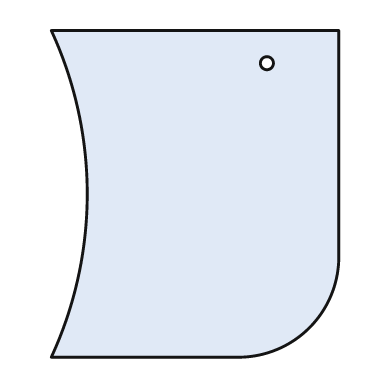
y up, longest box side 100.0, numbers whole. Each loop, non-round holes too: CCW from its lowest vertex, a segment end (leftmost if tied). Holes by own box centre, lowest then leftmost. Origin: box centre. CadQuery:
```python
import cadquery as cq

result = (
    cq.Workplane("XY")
    .moveTo(-44.0, -50.0)
    .lineTo(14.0, -50.0)
    .threePointArc((35.0, -41.0), (44.0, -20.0))
    .lineTo(44.0, 50.0)
    .lineTo(-44.0, 50.0)
    .threePointArc((-33.0, 0.0), (-44.0, -50.0))
    .close()
    .moveTo(22.0, 40.0)
    .circle(2.0)
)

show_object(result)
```